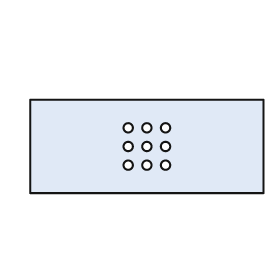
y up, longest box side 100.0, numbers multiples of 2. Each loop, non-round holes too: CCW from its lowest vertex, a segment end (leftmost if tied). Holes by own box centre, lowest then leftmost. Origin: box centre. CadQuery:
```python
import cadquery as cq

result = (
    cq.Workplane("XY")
    .moveTo(-50.0, -20.0)
    .lineTo(50.0, -20.0)
    .lineTo(50.0, 20.0)
    .lineTo(-50.0, 20.0)
    .close()
    .moveTo(-8.0, -8.0)
    .circle(2.0)
    .moveTo(0.0, -8.0)
    .circle(2.0)
    .moveTo(8.0, -8.0)
    .circle(2.0)
    .moveTo(-8.0, 0.0)
    .circle(2.0)
    .moveTo(0.0, 0.0)
    .circle(2.0)
    .moveTo(8.0, 0.0)
    .circle(2.0)
    .moveTo(-8.0, 8.0)
    .circle(2.0)
    .moveTo(0.0, 8.0)
    .circle(2.0)
    .moveTo(8.0, 8.0)
    .circle(2.0)
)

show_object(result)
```